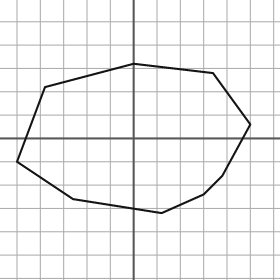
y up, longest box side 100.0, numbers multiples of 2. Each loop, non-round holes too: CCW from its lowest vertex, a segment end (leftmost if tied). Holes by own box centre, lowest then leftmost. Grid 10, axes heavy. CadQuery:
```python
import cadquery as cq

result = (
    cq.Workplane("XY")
    .moveTo(12.0, -32.0)
    .lineTo(30.0, -24.0)
    .lineTo(38.0, -16.0)
    .lineTo(50.0, 6.0)
    .lineTo(34.0, 28.0)
    .lineTo(0.0, 32.0)
    .lineTo(-38.0, 22.0)
    .lineTo(-50.0, -10.0)
    .lineTo(-26.0, -26.0)
    .close()
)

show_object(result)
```